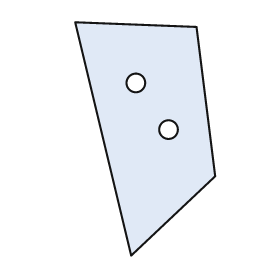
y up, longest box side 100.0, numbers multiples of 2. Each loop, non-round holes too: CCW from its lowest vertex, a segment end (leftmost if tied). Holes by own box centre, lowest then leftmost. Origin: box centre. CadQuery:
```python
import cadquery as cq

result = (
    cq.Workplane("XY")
    .moveTo(-6.0, -50.0)
    .lineTo(30.0, -16.0)
    .lineTo(22.0, 48.0)
    .lineTo(-30.0, 50.0)
    .close()
    .moveTo(10.0, 4.0)
    .circle(4.0)
    .moveTo(-4.0, 24.0)
    .circle(4.0)
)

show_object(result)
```